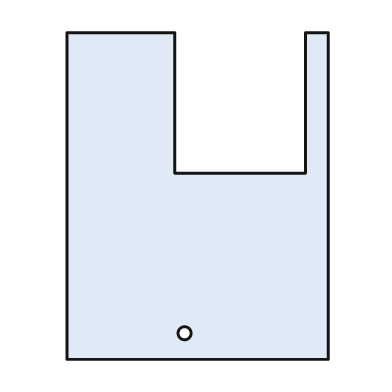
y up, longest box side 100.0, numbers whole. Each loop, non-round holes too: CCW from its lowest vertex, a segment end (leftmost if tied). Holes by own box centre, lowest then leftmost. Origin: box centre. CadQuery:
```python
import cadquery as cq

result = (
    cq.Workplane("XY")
    .moveTo(-40.0, -50.0)
    .lineTo(40.0, -50.0)
    .lineTo(40.0, 50.0)
    .lineTo(33.0, 50.0)
    .lineTo(33.0, 7.0)
    .lineTo(-7.0, 7.0)
    .lineTo(-7.0, 50.0)
    .lineTo(-40.0, 50.0)
    .close()
    .moveTo(-4.0, -42.0)
    .circle(2.0)
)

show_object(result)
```